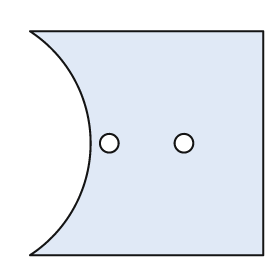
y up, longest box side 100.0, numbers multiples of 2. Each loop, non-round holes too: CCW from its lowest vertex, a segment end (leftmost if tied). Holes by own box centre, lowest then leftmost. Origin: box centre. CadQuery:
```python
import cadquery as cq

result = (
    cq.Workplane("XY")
    .moveTo(-50.0, -48.0)
    .lineTo(50.0, -48.0)
    .lineTo(50.0, 48.0)
    .lineTo(-50.0, 48.0)
    .threePointArc((-24.0, 0.0), (-50.0, -48.0))
    .close()
    .moveTo(-16.0, 0.0)
    .circle(4.0)
    .moveTo(16.0, 0.0)
    .circle(4.0)
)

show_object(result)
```